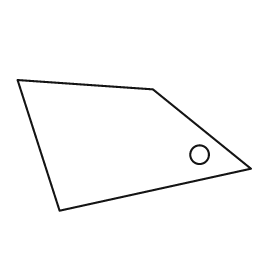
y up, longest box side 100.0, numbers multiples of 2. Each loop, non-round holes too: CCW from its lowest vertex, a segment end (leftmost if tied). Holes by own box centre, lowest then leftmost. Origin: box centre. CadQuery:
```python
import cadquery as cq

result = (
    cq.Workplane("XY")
    .moveTo(-32.0, -28.0)
    .lineTo(50.0, -10.0)
    .lineTo(8.0, 24.0)
    .lineTo(-50.0, 28.0)
    .close()
    .moveTo(28.0, -4.0)
    .circle(4.0)
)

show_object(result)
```